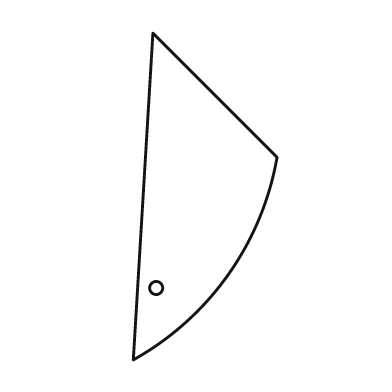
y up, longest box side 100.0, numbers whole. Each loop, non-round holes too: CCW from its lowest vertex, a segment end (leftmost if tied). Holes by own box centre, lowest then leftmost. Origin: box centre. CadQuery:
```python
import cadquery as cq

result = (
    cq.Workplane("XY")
    .moveTo(-22.0, -50.0)
    .threePointArc((7.0, -24.0), (22.0, 12.0))
    .lineTo(-16.0, 50.0)
    .close()
    .moveTo(-15.0, -28.0)
    .circle(2.0)
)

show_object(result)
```